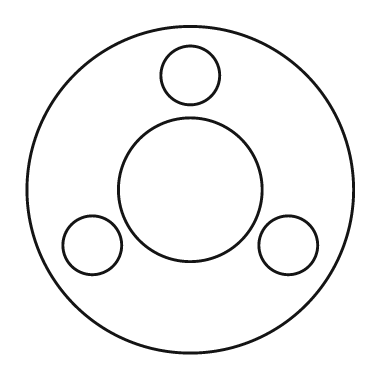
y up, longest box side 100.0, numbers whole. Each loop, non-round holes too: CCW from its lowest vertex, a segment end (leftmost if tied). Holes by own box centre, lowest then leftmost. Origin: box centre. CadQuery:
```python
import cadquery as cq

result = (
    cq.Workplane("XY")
    .moveTo(0.0, 0.0)
    .circle(50.0)
    .moveTo(-30.0, -17.0)
    .circle(9.0)
    .moveTo(30.0, -17.0)
    .circle(9.0)
    .moveTo(0.0, 0.0)
    .circle(22.0)
    .moveTo(0.0, 35.0)
    .circle(9.0)
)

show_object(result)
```